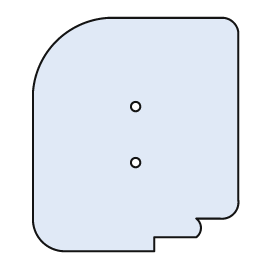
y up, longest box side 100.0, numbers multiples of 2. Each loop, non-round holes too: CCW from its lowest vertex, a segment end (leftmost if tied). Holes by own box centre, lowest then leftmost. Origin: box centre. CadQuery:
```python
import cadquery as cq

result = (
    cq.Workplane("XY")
    .moveTo(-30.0, -50.0)
    .lineTo(8.0, -50.0)
    .lineTo(8.0, -44.0)
    .lineTo(26.0, -44.0)
    .threePointArc((28.0, -40.0), (26.0, -36.0))
    .lineTo(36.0, -36.0)
    .threePointArc((42.0, -34.0), (44.0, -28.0))
    .lineTo(44.0, 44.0)
    .threePointArc((42.0, 48.0), (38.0, 50.0))
    .lineTo(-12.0, 50.0)
    .threePointArc((-34.0, 40.0), (-44.0, 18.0))
    .lineTo(-44.0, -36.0)
    .threePointArc((-40.0, -46.0), (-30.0, -50.0))
    .close()
    .moveTo(0.0, -12.0)
    .circle(2.0)
    .moveTo(0.0, 12.0)
    .circle(2.0)
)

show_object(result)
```